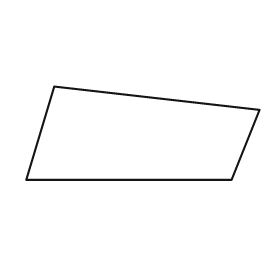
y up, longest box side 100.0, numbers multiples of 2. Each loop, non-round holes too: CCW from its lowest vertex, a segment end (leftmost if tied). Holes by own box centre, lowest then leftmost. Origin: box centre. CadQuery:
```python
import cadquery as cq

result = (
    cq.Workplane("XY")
    .moveTo(-50.0, -20.0)
    .lineTo(38.0, -20.0)
    .lineTo(50.0, 10.0)
    .lineTo(-38.0, 20.0)
    .close()
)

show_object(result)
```